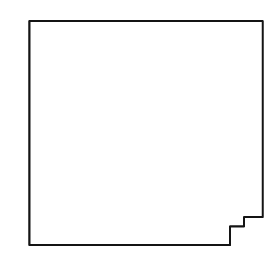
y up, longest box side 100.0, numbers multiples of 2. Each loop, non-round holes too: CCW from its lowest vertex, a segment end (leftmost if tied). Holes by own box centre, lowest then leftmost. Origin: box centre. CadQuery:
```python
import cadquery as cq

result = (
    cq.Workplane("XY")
    .moveTo(-50.0, -48.0)
    .lineTo(36.0, -48.0)
    .lineTo(36.0, -40.0)
    .lineTo(42.0, -40.0)
    .lineTo(42.0, -36.0)
    .lineTo(50.0, -36.0)
    .lineTo(50.0, 48.0)
    .lineTo(-50.0, 48.0)
    .close()
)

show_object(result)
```